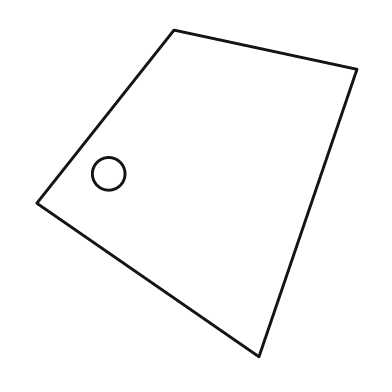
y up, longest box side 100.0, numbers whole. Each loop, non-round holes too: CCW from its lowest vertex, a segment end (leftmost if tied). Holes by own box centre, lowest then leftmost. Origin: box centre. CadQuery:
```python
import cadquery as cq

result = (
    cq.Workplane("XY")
    .moveTo(19.0, -50.0)
    .lineTo(49.0, 38.0)
    .lineTo(-7.0, 50.0)
    .lineTo(-49.0, -3.0)
    .close()
    .moveTo(-27.0, 6.0)
    .circle(5.0)
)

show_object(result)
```